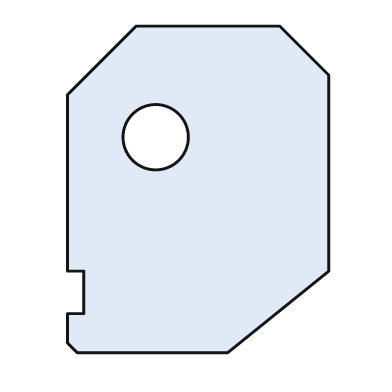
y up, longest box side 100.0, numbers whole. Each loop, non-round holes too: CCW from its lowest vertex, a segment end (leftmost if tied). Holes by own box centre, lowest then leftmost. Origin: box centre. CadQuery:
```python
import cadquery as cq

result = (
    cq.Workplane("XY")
    .moveTo(-37.0, -50.0)
    .lineTo(9.0, -50.0)
    .lineTo(40.0, -25.0)
    .lineTo(40.0, 35.0)
    .lineTo(25.0, 50.0)
    .lineTo(-19.0, 50.0)
    .lineTo(-40.0, 29.0)
    .lineTo(-40.0, -25.0)
    .lineTo(-35.0, -25.0)
    .lineTo(-35.0, -38.0)
    .lineTo(-40.0, -38.0)
    .lineTo(-40.0, -47.0)
    .close()
    .moveTo(-13.0, 16.0)
    .circle(10.0)
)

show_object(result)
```